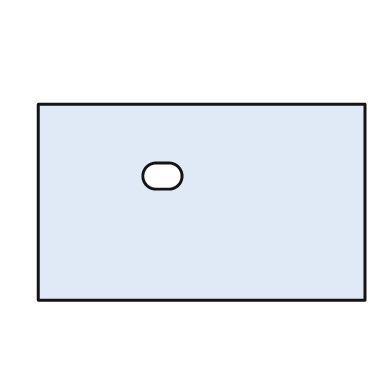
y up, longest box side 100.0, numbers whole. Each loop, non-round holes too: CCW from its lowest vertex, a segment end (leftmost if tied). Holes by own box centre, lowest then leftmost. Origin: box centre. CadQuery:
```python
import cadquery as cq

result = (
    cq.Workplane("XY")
    .moveTo(-50.0, -30.0)
    .lineTo(50.0, -30.0)
    .lineTo(50.0, 30.0)
    .lineTo(-50.0, 30.0)
    .close()
    .moveTo(-14.0, 4.0)
    .lineTo(-10.0, 4.0)
    .threePointArc((-6.0, 8.0), (-10.0, 12.0))
    .lineTo(-14.0, 12.0)
    .threePointArc((-18.0, 8.0), (-14.0, 4.0))
    .close()
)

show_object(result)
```